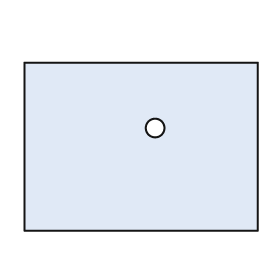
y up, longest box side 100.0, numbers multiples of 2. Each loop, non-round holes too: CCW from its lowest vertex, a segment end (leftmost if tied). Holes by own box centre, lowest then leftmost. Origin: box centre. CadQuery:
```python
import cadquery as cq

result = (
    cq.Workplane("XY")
    .moveTo(-50.0, -36.0)
    .lineTo(50.0, -36.0)
    .lineTo(50.0, 36.0)
    .lineTo(-50.0, 36.0)
    .close()
    .moveTo(6.0, 8.0)
    .circle(4.0)
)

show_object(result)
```